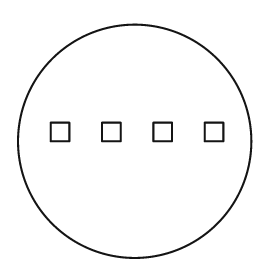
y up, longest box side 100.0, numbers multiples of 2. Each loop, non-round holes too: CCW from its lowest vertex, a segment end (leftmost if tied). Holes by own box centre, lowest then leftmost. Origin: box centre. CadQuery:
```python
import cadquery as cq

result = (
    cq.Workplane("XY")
    .moveTo(0.0, 0.0)
    .circle(50.0)
    .moveTo(-36.0, 0.0)
    .lineTo(-28.0, 0.0)
    .lineTo(-28.0, 8.0)
    .lineTo(-36.0, 8.0)
    .close()
    .moveTo(-14.0, 0.0)
    .lineTo(-6.0, 0.0)
    .lineTo(-6.0, 8.0)
    .lineTo(-14.0, 8.0)
    .close()
    .moveTo(8.0, 0.0)
    .lineTo(16.0, 0.0)
    .lineTo(16.0, 8.0)
    .lineTo(8.0, 8.0)
    .close()
    .moveTo(30.0, 0.0)
    .lineTo(38.0, 0.0)
    .lineTo(38.0, 8.0)
    .lineTo(30.0, 8.0)
    .close()
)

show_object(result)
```